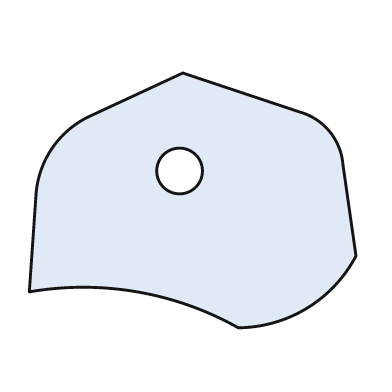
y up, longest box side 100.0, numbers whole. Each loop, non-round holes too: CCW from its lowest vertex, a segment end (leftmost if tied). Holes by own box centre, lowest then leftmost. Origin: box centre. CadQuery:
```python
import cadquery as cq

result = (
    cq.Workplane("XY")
    .moveTo(14.0, -39.0)
    .threePointArc((35.0, -33.0), (50.0, -17.0))
    .lineTo(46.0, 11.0)
    .threePointArc((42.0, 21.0), (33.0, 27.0))
    .lineTo(-3.0, 39.0)
    .lineTo(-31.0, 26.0)
    .threePointArc((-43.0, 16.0), (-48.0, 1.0))
    .lineTo(-50.0, -28.0)
    .threePointArc((-17.0, -28.0), (14.0, -39.0))
    .close()
    .moveTo(-4.0, 9.0)
    .circle(7.0)
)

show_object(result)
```